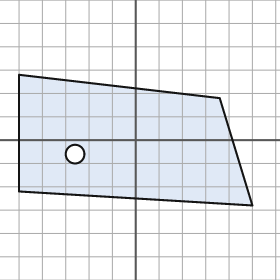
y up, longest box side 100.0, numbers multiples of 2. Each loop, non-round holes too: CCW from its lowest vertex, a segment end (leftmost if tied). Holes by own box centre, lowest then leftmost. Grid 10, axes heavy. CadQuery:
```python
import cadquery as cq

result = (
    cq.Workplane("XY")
    .moveTo(50.0, -28.0)
    .lineTo(36.0, 18.0)
    .lineTo(-50.0, 28.0)
    .lineTo(-50.0, -22.0)
    .close()
    .moveTo(-26.0, -6.0)
    .circle(4.0)
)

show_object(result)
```